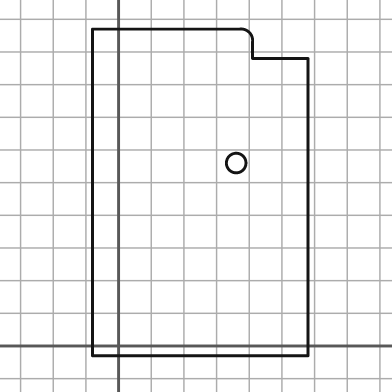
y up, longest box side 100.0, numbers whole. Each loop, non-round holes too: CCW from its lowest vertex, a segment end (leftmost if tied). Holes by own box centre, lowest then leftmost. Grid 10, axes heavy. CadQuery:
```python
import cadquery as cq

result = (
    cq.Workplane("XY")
    .moveTo(-8.0, -3.0)
    .lineTo(58.0, -3.0)
    .lineTo(58.0, 88.0)
    .lineTo(41.0, 88.0)
    .lineTo(41.0, 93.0)
    .threePointArc((40.0, 96.0), (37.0, 97.0))
    .lineTo(-8.0, 97.0)
    .close()
    .moveTo(36.0, 56.0)
    .circle(3.0)
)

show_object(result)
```